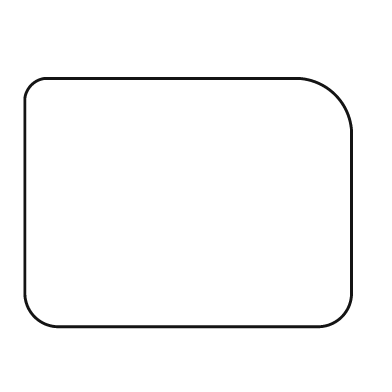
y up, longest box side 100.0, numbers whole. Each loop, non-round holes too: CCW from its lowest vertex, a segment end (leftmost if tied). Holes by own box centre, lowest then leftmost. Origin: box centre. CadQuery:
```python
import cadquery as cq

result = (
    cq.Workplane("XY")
    .moveTo(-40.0, -38.0)
    .lineTo(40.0, -38.0)
    .threePointArc((47.0, -35.0), (50.0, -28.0))
    .lineTo(50.0, 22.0)
    .threePointArc((45.0, 33.0), (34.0, 38.0))
    .lineTo(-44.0, 38.0)
    .threePointArc((-48.0, 36.0), (-50.0, 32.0))
    .lineTo(-50.0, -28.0)
    .threePointArc((-47.0, -35.0), (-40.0, -38.0))
    .close()
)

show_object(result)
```